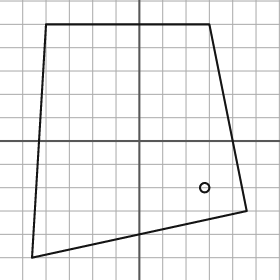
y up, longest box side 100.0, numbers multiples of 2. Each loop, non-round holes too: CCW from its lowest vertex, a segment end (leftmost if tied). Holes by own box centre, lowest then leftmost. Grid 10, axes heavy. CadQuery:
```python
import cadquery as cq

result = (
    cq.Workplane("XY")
    .moveTo(-46.0, -50.0)
    .lineTo(46.0, -30.0)
    .lineTo(30.0, 50.0)
    .lineTo(-40.0, 50.0)
    .close()
    .moveTo(28.0, -20.0)
    .circle(2.0)
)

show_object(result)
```